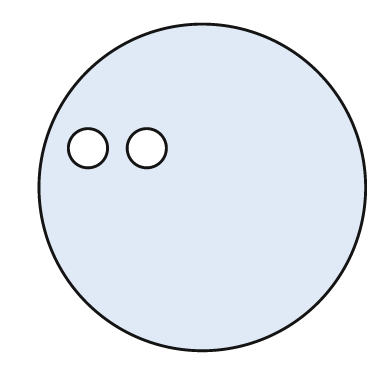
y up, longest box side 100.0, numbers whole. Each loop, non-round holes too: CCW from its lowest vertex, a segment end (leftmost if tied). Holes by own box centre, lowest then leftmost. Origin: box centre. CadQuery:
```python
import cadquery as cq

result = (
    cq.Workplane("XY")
    .moveTo(0.0, 0.0)
    .circle(50.0)
    .moveTo(-35.0, 12.0)
    .circle(6.0)
    .moveTo(-17.0, 12.0)
    .circle(6.0)
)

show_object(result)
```